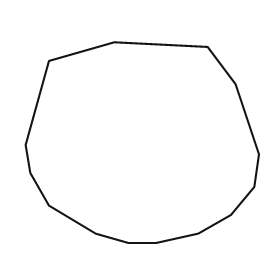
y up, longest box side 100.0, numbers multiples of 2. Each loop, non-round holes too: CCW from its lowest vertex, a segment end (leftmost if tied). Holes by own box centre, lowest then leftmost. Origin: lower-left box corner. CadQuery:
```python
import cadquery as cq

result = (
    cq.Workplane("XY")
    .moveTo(44.0, 0.0)
    .lineTo(56.0, 0.0)
    .lineTo(74.0, 4.0)
    .lineTo(88.0, 12.0)
    .lineTo(98.0, 24.0)
    .lineTo(100.0, 38.0)
    .lineTo(90.0, 68.0)
    .lineTo(78.0, 84.0)
    .lineTo(38.0, 86.0)
    .lineTo(10.0, 78.0)
    .lineTo(0.0, 42.0)
    .lineTo(2.0, 30.0)
    .lineTo(10.0, 16.0)
    .lineTo(30.0, 4.0)
    .close()
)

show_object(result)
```